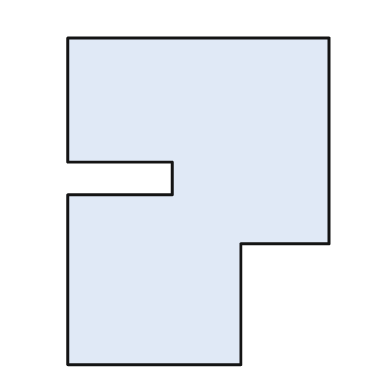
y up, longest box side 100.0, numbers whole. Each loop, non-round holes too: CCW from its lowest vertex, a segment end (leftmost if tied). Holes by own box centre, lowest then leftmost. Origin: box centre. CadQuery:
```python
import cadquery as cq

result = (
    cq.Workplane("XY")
    .moveTo(-40.0, -50.0)
    .lineTo(13.0, -50.0)
    .lineTo(13.0, -13.0)
    .lineTo(40.0, -13.0)
    .lineTo(40.0, 50.0)
    .lineTo(-40.0, 50.0)
    .lineTo(-40.0, 12.0)
    .lineTo(-8.0, 12.0)
    .lineTo(-8.0, 2.0)
    .lineTo(-40.0, 2.0)
    .close()
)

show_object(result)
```